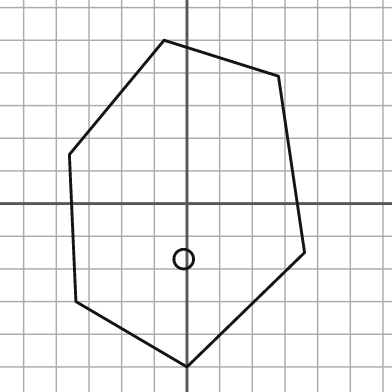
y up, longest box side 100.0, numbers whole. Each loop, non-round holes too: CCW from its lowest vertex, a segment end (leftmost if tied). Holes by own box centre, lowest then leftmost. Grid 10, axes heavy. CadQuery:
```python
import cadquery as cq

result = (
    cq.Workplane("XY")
    .moveTo(0.0, -50.0)
    .lineTo(36.0, -15.0)
    .lineTo(28.0, 39.0)
    .lineTo(-7.0, 50.0)
    .lineTo(-36.0, 15.0)
    .lineTo(-34.0, -30.0)
    .close()
    .moveTo(-1.0, -17.0)
    .circle(3.0)
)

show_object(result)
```